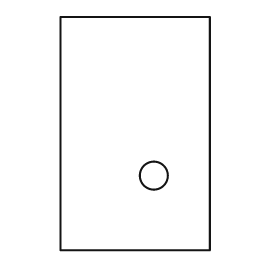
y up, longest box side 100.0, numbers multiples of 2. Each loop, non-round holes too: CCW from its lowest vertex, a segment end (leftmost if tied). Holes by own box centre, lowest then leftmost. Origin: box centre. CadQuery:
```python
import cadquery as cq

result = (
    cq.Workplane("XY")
    .moveTo(-32.0, -50.0)
    .lineTo(32.0, -50.0)
    .lineTo(32.0, 50.0)
    .lineTo(-32.0, 50.0)
    .close()
    .moveTo(8.0, -18.0)
    .circle(6.0)
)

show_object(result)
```